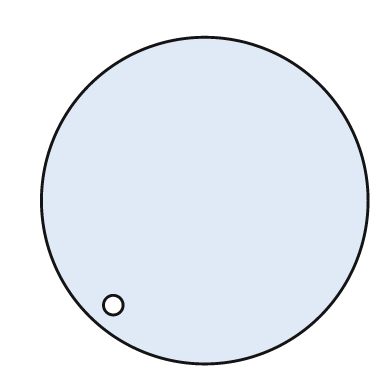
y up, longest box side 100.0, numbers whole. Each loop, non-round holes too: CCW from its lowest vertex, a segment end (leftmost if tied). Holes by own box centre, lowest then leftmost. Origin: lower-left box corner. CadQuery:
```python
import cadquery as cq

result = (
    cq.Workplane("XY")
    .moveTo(50.0, 50.0)
    .circle(50.0)
    .moveTo(22.0, 18.0)
    .circle(3.0)
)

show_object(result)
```